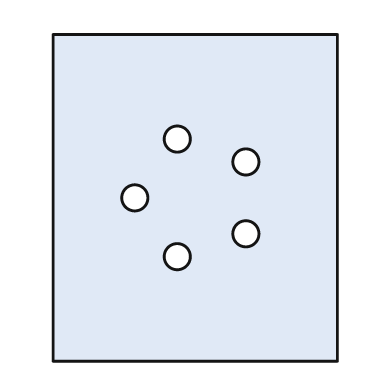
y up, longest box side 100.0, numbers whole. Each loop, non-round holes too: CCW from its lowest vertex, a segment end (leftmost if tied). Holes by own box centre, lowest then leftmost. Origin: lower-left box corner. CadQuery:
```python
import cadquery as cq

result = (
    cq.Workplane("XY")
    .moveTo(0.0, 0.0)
    .lineTo(87.0, 0.0)
    .lineTo(87.0, 100.0)
    .lineTo(0.0, 100.0)
    .close()
    .moveTo(38.0, 32.0)
    .circle(4.0)
    .moveTo(59.0, 39.0)
    .circle(4.0)
    .moveTo(25.0, 50.0)
    .circle(4.0)
    .moveTo(59.0, 61.0)
    .circle(4.0)
    .moveTo(38.0, 68.0)
    .circle(4.0)
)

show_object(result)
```